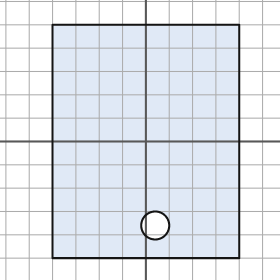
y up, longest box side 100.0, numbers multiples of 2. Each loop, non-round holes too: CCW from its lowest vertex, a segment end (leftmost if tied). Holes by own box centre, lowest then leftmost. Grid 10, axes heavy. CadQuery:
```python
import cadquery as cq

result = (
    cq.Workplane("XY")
    .moveTo(-40.0, -50.0)
    .lineTo(40.0, -50.0)
    .lineTo(40.0, 50.0)
    .lineTo(-40.0, 50.0)
    .close()
    .moveTo(4.0, -36.0)
    .circle(6.0)
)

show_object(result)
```